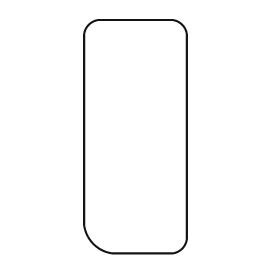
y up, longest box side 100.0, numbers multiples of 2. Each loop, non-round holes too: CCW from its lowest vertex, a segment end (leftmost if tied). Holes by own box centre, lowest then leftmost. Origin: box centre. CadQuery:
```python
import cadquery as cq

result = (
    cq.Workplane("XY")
    .moveTo(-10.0, -50.0)
    .lineTo(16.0, -50.0)
    .threePointArc((20.0, -48.0), (22.0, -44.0))
    .lineTo(22.0, 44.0)
    .threePointArc((20.0, 48.0), (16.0, 50.0))
    .lineTo(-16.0, 50.0)
    .threePointArc((-20.0, 48.0), (-22.0, 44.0))
    .lineTo(-22.0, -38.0)
    .threePointArc((-18.0, -46.0), (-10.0, -50.0))
    .close()
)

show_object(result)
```